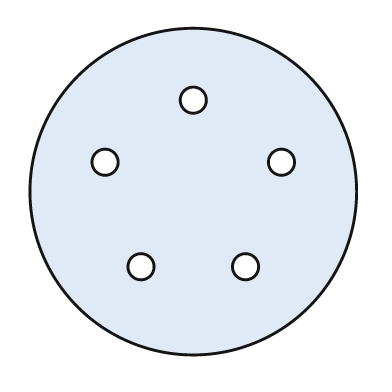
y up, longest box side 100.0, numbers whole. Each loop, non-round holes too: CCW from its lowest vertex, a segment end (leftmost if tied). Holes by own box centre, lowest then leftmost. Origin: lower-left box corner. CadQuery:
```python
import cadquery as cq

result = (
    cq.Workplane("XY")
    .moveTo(50.0, 50.0)
    .circle(50.0)
    .moveTo(34.0, 27.0)
    .circle(4.0)
    .moveTo(66.0, 27.0)
    .circle(4.0)
    .moveTo(23.0, 59.0)
    .circle(4.0)
    .moveTo(77.0, 59.0)
    .circle(4.0)
    .moveTo(50.0, 78.0)
    .circle(4.0)
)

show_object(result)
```